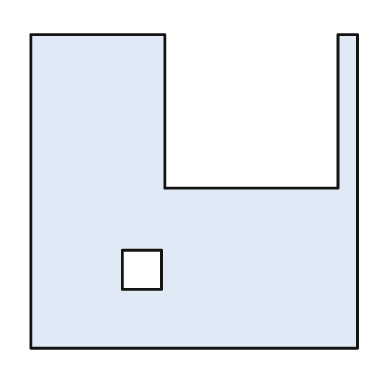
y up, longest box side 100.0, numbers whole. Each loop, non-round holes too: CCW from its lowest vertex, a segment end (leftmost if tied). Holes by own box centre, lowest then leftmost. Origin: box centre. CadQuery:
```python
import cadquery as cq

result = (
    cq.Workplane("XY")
    .moveTo(-50.0, -48.0)
    .lineTo(50.0, -48.0)
    .lineTo(50.0, 48.0)
    .lineTo(44.0, 48.0)
    .lineTo(44.0, 1.0)
    .lineTo(-9.0, 1.0)
    .lineTo(-9.0, 48.0)
    .lineTo(-50.0, 48.0)
    .close()
    .moveTo(-22.0, -30.0)
    .lineTo(-10.0, -30.0)
    .lineTo(-10.0, -18.0)
    .lineTo(-22.0, -18.0)
    .close()
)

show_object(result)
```